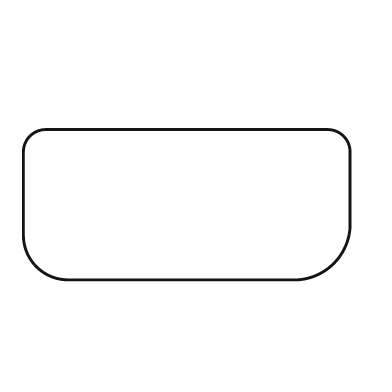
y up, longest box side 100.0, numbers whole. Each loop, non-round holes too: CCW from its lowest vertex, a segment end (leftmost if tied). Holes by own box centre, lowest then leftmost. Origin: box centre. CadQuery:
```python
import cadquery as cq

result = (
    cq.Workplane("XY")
    .moveTo(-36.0, -23.0)
    .lineTo(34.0, -23.0)
    .threePointArc((45.0, -18.0), (50.0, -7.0))
    .lineTo(50.0, 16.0)
    .threePointArc((48.0, 21.0), (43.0, 23.0))
    .lineTo(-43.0, 23.0)
    .threePointArc((-48.0, 21.0), (-50.0, 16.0))
    .lineTo(-50.0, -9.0)
    .threePointArc((-46.0, -19.0), (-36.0, -23.0))
    .close()
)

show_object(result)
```